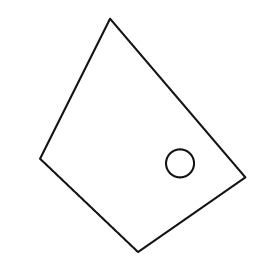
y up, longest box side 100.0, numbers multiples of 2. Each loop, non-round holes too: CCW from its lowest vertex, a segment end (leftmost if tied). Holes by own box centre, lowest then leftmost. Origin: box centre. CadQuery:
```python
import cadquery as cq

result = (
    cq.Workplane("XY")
    .moveTo(-2.0, -50.0)
    .lineTo(44.0, -18.0)
    .lineTo(-14.0, 50.0)
    .lineTo(-44.0, -10.0)
    .close()
    .moveTo(16.0, -12.0)
    .circle(6.0)
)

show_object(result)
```